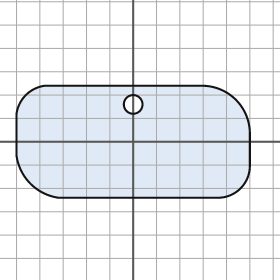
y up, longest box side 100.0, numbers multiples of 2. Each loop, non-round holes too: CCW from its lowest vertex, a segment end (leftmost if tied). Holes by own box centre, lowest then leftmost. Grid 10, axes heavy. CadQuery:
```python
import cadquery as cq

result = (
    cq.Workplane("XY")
    .moveTo(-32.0, -24.0)
    .lineTo(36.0, -24.0)
    .threePointArc((46.0, -20.0), (50.0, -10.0))
    .lineTo(50.0, 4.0)
    .threePointArc((44.0, 18.0), (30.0, 24.0))
    .lineTo(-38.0, 24.0)
    .threePointArc((-46.0, 20.0), (-50.0, 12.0))
    .lineTo(-50.0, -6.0)
    .threePointArc((-44.0, -18.0), (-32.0, -24.0))
    .close()
    .moveTo(0.0, 16.0)
    .circle(4.0)
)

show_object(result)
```